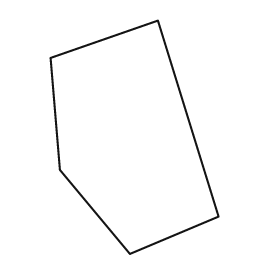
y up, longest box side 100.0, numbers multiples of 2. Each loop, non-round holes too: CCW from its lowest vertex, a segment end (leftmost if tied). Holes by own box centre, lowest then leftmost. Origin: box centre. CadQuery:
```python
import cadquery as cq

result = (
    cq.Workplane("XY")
    .moveTo(-2.0, -50.0)
    .lineTo(36.0, -34.0)
    .lineTo(10.0, 50.0)
    .lineTo(-36.0, 34.0)
    .lineTo(-32.0, -14.0)
    .close()
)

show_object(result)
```